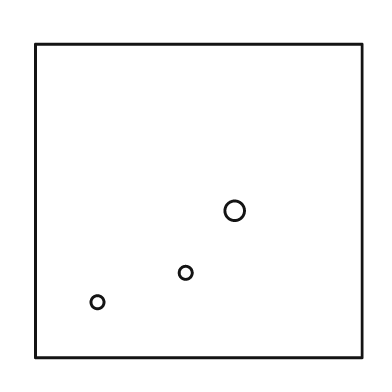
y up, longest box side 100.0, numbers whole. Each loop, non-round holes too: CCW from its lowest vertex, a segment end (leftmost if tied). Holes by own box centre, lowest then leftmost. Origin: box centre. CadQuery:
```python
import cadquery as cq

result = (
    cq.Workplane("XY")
    .moveTo(-50.0, -48.0)
    .lineTo(50.0, -48.0)
    .lineTo(50.0, 48.0)
    .lineTo(-50.0, 48.0)
    .close()
    .moveTo(-31.0, -31.0)
    .circle(2.0)
    .moveTo(-4.0, -22.0)
    .circle(2.0)
    .moveTo(11.0, -3.0)
    .circle(3.0)
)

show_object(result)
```